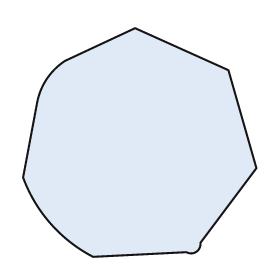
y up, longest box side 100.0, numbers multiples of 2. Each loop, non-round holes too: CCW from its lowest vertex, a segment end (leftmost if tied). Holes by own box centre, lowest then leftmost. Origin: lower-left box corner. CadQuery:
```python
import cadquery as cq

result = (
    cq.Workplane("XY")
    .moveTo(30.0, 0.0)
    .lineTo(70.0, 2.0)
    .threePointArc((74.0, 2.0), (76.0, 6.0))
    .lineTo(100.0, 38.0)
    .lineTo(88.0, 80.0)
    .lineTo(48.0, 98.0)
    .lineTo(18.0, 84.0)
    .threePointArc((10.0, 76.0), (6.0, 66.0))
    .lineTo(0.0, 34.0)
    .threePointArc((12.0, 14.0), (30.0, 0.0))
    .close()
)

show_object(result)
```